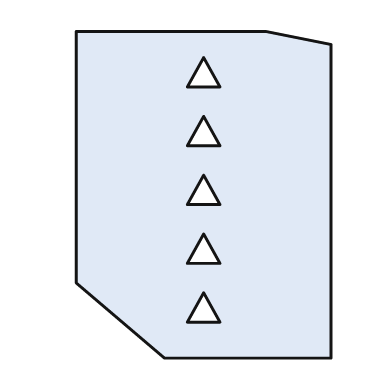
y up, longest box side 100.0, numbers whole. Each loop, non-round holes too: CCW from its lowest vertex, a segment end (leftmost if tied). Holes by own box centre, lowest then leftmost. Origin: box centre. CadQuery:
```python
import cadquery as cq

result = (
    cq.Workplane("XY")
    .moveTo(-12.0, -50.0)
    .lineTo(39.0, -50.0)
    .lineTo(39.0, 46.0)
    .lineTo(19.0, 50.0)
    .lineTo(-39.0, 50.0)
    .lineTo(-39.0, -27.0)
    .close()
    .moveTo(-5.0, -39.0)
    .lineTo(5.0, -39.0)
    .lineTo(0.0, -30.0)
    .close()
    .moveTo(-5.0, -21.0)
    .lineTo(5.0, -21.0)
    .lineTo(0.0, -12.0)
    .close()
    .moveTo(-5.0, -3.0)
    .lineTo(5.0, -3.0)
    .lineTo(0.0, 6.0)
    .close()
    .moveTo(-5.0, 15.0)
    .lineTo(5.0, 15.0)
    .lineTo(0.0, 24.0)
    .close()
    .moveTo(-5.0, 33.0)
    .lineTo(5.0, 33.0)
    .lineTo(0.0, 42.0)
    .close()
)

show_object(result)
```